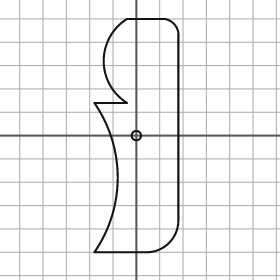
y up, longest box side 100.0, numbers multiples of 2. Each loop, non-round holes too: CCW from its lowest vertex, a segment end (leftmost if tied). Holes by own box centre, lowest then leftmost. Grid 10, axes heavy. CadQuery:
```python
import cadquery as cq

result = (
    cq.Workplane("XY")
    .moveTo(-18.0, -50.0)
    .lineTo(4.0, -50.0)
    .threePointArc((14.0, -46.0), (18.0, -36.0))
    .lineTo(18.0, 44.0)
    .threePointArc((16.0, 48.0), (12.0, 50.0))
    .lineTo(-4.0, 50.0)
    .threePointArc((-14.0, 32.0), (-4.0, 14.0))
    .lineTo(-18.0, 14.0)
    .threePointArc((-8.0, -18.0), (-18.0, -50.0))
    .close()
    .moveTo(0.0, 0.0)
    .circle(2.0)
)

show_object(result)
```